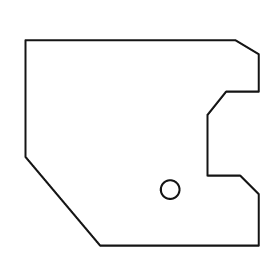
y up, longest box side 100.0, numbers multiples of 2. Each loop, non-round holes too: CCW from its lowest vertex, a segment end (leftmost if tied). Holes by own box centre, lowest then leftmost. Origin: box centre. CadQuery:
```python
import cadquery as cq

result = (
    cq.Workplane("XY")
    .moveTo(-18.0, -44.0)
    .lineTo(50.0, -44.0)
    .lineTo(50.0, -22.0)
    .lineTo(42.0, -14.0)
    .lineTo(28.0, -14.0)
    .lineTo(28.0, 12.0)
    .lineTo(36.0, 22.0)
    .lineTo(50.0, 22.0)
    .lineTo(50.0, 38.0)
    .lineTo(40.0, 44.0)
    .lineTo(-50.0, 44.0)
    .lineTo(-50.0, -6.0)
    .close()
    .moveTo(12.0, -20.0)
    .circle(4.0)
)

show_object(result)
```